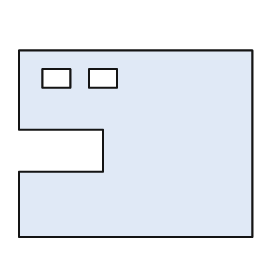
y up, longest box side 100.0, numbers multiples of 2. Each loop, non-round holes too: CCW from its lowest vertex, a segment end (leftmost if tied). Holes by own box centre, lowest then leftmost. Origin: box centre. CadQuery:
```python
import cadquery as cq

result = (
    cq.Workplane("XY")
    .moveTo(-50.0, -40.0)
    .lineTo(50.0, -40.0)
    .lineTo(50.0, 40.0)
    .lineTo(-50.0, 40.0)
    .lineTo(-50.0, 6.0)
    .lineTo(-14.0, 6.0)
    .lineTo(-14.0, -12.0)
    .lineTo(-50.0, -12.0)
    .close()
    .moveTo(-40.0, 24.0)
    .lineTo(-28.0, 24.0)
    .lineTo(-28.0, 32.0)
    .lineTo(-40.0, 32.0)
    .close()
    .moveTo(-20.0, 24.0)
    .lineTo(-8.0, 24.0)
    .lineTo(-8.0, 32.0)
    .lineTo(-20.0, 32.0)
    .close()
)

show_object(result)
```